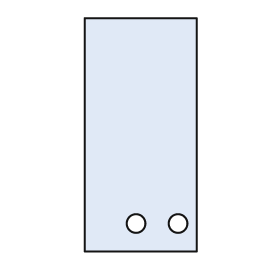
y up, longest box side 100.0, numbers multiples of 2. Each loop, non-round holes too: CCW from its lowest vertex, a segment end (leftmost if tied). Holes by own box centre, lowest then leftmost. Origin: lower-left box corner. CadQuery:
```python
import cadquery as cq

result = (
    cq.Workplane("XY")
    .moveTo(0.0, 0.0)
    .lineTo(48.0, 0.0)
    .lineTo(48.0, 100.0)
    .lineTo(0.0, 100.0)
    .close()
    .moveTo(22.0, 12.0)
    .circle(4.0)
    .moveTo(40.0, 12.0)
    .circle(4.0)
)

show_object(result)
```